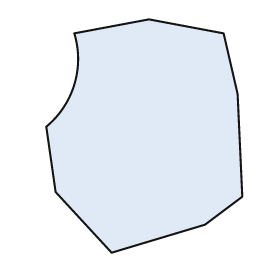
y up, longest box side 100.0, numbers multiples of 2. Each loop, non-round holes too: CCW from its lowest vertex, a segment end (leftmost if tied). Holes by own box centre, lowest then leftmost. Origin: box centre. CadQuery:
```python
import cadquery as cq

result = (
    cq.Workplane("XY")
    .moveTo(-14.0, -50.0)
    .lineTo(26.0, -38.0)
    .lineTo(42.0, -26.0)
    .lineTo(40.0, 18.0)
    .lineTo(34.0, 44.0)
    .lineTo(2.0, 50.0)
    .lineTo(-30.0, 44.0)
    .threePointArc((-30.0, 22.0), (-42.0, 4.0))
    .lineTo(-38.0, -24.0)
    .close()
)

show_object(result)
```